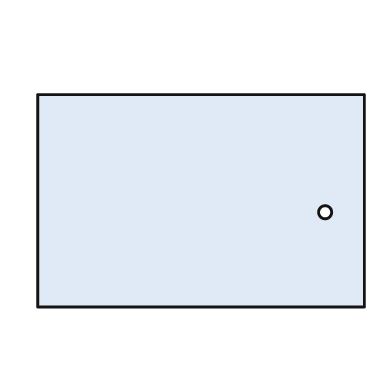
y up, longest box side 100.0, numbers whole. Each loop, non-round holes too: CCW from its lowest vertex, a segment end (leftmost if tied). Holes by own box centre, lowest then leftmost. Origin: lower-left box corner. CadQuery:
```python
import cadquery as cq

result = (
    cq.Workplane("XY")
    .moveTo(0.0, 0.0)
    .lineTo(100.0, 0.0)
    .lineTo(100.0, 65.0)
    .lineTo(0.0, 65.0)
    .close()
    .moveTo(88.0, 29.0)
    .circle(2.0)
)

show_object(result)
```